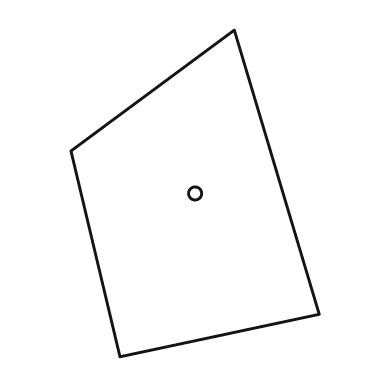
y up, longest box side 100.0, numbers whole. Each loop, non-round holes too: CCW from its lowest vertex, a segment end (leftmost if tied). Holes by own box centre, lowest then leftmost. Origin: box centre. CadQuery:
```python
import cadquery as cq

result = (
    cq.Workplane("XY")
    .moveTo(-23.0, -50.0)
    .lineTo(38.0, -37.0)
    .lineTo(12.0, 50.0)
    .lineTo(-38.0, 13.0)
    .close()
    .moveTo(0.0, 0.0)
    .circle(2.0)
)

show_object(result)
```